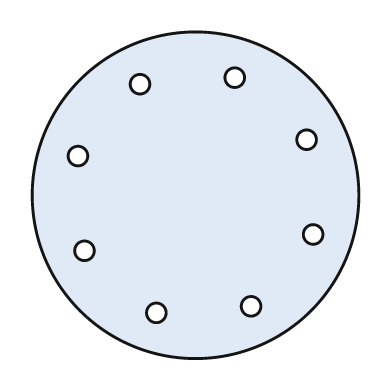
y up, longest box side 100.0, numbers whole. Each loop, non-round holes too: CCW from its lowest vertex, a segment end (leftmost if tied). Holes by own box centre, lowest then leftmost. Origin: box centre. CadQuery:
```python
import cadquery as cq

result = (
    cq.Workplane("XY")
    .moveTo(0.0, 0.0)
    .circle(50.0)
    .moveTo(-12.0, -36.0)
    .circle(3.0)
    .moveTo(17.0, -34.0)
    .circle(3.0)
    .moveTo(-34.0, -17.0)
    .circle(3.0)
    .moveTo(36.0, -12.0)
    .circle(3.0)
    .moveTo(-36.0, 12.0)
    .circle(3.0)
    .moveTo(34.0, 17.0)
    .circle(3.0)
    .moveTo(-17.0, 34.0)
    .circle(3.0)
    .moveTo(12.0, 36.0)
    .circle(3.0)
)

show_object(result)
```